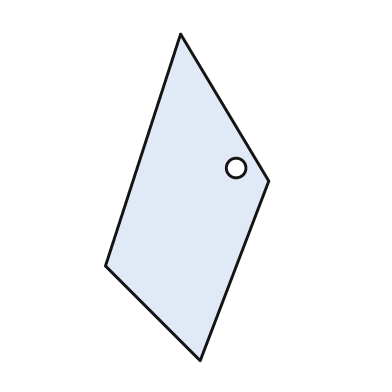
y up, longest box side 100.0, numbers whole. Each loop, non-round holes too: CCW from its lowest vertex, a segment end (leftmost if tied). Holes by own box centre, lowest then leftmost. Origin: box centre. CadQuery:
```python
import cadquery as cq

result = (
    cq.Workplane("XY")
    .moveTo(4.0, -50.0)
    .lineTo(25.0, 5.0)
    .lineTo(-2.0, 50.0)
    .lineTo(-25.0, -21.0)
    .close()
    .moveTo(15.0, 9.0)
    .circle(3.0)
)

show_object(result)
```